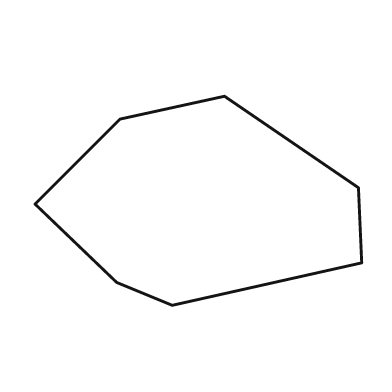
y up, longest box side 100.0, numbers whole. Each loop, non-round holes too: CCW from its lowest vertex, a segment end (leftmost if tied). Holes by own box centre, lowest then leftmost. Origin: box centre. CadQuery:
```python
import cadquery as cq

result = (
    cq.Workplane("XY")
    .moveTo(-8.0, -32.0)
    .lineTo(50.0, -19.0)
    .lineTo(49.0, 4.0)
    .lineTo(8.0, 32.0)
    .lineTo(-24.0, 25.0)
    .lineTo(-50.0, -1.0)
    .lineTo(-25.0, -25.0)
    .close()
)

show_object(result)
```